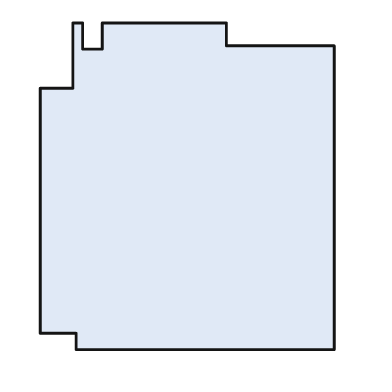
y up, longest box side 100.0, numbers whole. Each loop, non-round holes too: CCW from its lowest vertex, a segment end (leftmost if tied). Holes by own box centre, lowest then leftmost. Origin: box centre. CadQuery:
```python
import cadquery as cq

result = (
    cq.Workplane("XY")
    .moveTo(-34.0, -50.0)
    .lineTo(45.0, -50.0)
    .lineTo(45.0, 43.0)
    .lineTo(12.0, 43.0)
    .lineTo(12.0, 50.0)
    .lineTo(-26.0, 50.0)
    .lineTo(-26.0, 42.0)
    .lineTo(-32.0, 42.0)
    .lineTo(-32.0, 50.0)
    .lineTo(-35.0, 50.0)
    .lineTo(-35.0, 30.0)
    .lineTo(-45.0, 30.0)
    .lineTo(-45.0, -45.0)
    .lineTo(-34.0, -45.0)
    .close()
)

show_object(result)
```